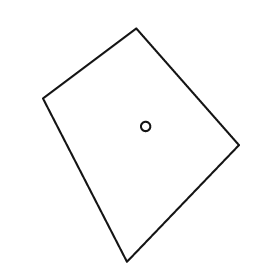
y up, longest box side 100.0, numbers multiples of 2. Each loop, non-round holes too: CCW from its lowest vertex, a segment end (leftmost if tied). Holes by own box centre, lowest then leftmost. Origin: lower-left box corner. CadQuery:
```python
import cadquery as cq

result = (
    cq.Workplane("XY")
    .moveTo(36.0, 0.0)
    .lineTo(84.0, 50.0)
    .lineTo(40.0, 100.0)
    .lineTo(0.0, 70.0)
    .close()
    .moveTo(44.0, 58.0)
    .circle(2.0)
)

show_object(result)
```